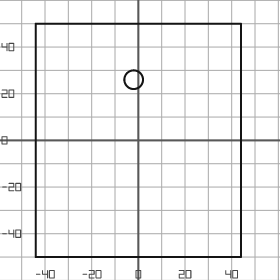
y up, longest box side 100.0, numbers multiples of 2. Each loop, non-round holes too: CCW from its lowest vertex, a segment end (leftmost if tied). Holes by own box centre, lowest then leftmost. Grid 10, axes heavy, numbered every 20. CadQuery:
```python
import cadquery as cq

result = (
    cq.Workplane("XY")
    .moveTo(-44.0, -50.0)
    .lineTo(44.0, -50.0)
    .lineTo(44.0, 50.0)
    .lineTo(-44.0, 50.0)
    .close()
    .moveTo(-2.0, 26.0)
    .circle(4.0)
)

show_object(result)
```